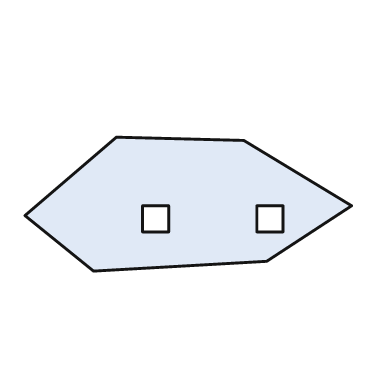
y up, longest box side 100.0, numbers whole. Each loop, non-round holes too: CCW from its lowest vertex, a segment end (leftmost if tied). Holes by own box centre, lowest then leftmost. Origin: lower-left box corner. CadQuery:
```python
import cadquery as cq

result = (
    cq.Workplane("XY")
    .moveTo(21.0, 0.0)
    .lineTo(74.0, 3.0)
    .lineTo(100.0, 20.0)
    .lineTo(67.0, 40.0)
    .lineTo(28.0, 41.0)
    .lineTo(0.0, 17.0)
    .close()
    .moveTo(36.0, 12.0)
    .lineTo(44.0, 12.0)
    .lineTo(44.0, 20.0)
    .lineTo(36.0, 20.0)
    .close()
    .moveTo(71.0, 12.0)
    .lineTo(79.0, 12.0)
    .lineTo(79.0, 20.0)
    .lineTo(71.0, 20.0)
    .close()
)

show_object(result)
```